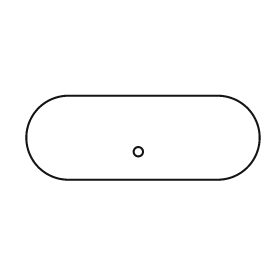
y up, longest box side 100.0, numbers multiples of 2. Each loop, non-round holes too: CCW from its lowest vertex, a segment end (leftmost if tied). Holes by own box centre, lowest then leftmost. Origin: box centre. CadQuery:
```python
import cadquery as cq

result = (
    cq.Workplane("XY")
    .moveTo(-32.0, -18.0)
    .lineTo(32.0, -18.0)
    .threePointArc((50.0, 0.0), (32.0, 18.0))
    .lineTo(-32.0, 18.0)
    .threePointArc((-50.0, 0.0), (-32.0, -18.0))
    .close()
    .moveTo(-2.0, -6.0)
    .circle(2.0)
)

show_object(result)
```